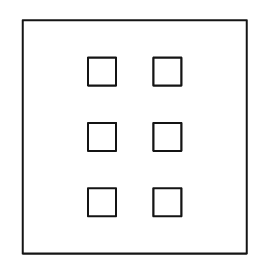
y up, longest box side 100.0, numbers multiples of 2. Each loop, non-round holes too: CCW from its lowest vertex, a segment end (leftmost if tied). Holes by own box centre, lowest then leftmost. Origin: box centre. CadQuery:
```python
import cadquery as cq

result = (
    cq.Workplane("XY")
    .moveTo(-48.0, -50.0)
    .lineTo(48.0, -50.0)
    .lineTo(48.0, 50.0)
    .lineTo(-48.0, 50.0)
    .close()
    .moveTo(-20.0, -34.0)
    .lineTo(-8.0, -34.0)
    .lineTo(-8.0, -22.0)
    .lineTo(-20.0, -22.0)
    .close()
    .moveTo(8.0, -34.0)
    .lineTo(20.0, -34.0)
    .lineTo(20.0, -22.0)
    .lineTo(8.0, -22.0)
    .close()
    .moveTo(-20.0, -6.0)
    .lineTo(-8.0, -6.0)
    .lineTo(-8.0, 6.0)
    .lineTo(-20.0, 6.0)
    .close()
    .moveTo(8.0, -6.0)
    .lineTo(20.0, -6.0)
    .lineTo(20.0, 6.0)
    .lineTo(8.0, 6.0)
    .close()
    .moveTo(-20.0, 22.0)
    .lineTo(-8.0, 22.0)
    .lineTo(-8.0, 34.0)
    .lineTo(-20.0, 34.0)
    .close()
    .moveTo(8.0, 22.0)
    .lineTo(20.0, 22.0)
    .lineTo(20.0, 34.0)
    .lineTo(8.0, 34.0)
    .close()
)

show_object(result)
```